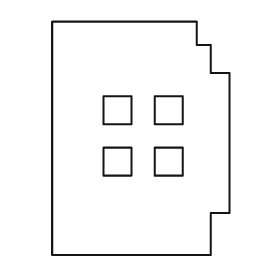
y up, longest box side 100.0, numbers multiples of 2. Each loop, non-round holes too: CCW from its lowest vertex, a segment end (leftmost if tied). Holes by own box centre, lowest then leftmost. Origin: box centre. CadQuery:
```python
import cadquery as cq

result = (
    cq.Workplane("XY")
    .moveTo(-38.0, -50.0)
    .lineTo(30.0, -50.0)
    .lineTo(30.0, -32.0)
    .lineTo(38.0, -32.0)
    .lineTo(38.0, 28.0)
    .lineTo(30.0, 28.0)
    .lineTo(30.0, 40.0)
    .lineTo(24.0, 40.0)
    .lineTo(24.0, 50.0)
    .lineTo(-38.0, 50.0)
    .close()
    .moveTo(-16.0, -16.0)
    .lineTo(-4.0, -16.0)
    .lineTo(-4.0, -4.0)
    .lineTo(-16.0, -4.0)
    .close()
    .moveTo(6.0, -16.0)
    .lineTo(18.0, -16.0)
    .lineTo(18.0, -4.0)
    .lineTo(6.0, -4.0)
    .close()
    .moveTo(-16.0, 6.0)
    .lineTo(-4.0, 6.0)
    .lineTo(-4.0, 18.0)
    .lineTo(-16.0, 18.0)
    .close()
    .moveTo(6.0, 6.0)
    .lineTo(18.0, 6.0)
    .lineTo(18.0, 18.0)
    .lineTo(6.0, 18.0)
    .close()
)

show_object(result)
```